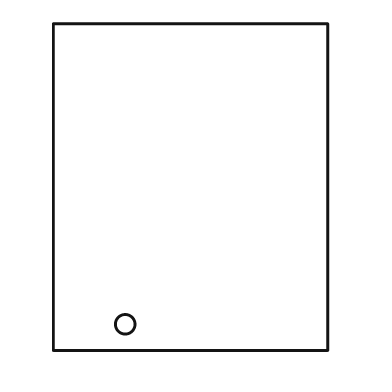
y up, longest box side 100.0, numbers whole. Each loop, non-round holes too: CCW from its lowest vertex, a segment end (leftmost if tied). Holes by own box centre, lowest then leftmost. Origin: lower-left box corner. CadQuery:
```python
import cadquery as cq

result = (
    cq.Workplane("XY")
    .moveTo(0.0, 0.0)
    .lineTo(84.0, 0.0)
    .lineTo(84.0, 100.0)
    .lineTo(0.0, 100.0)
    .close()
    .moveTo(22.0, 8.0)
    .circle(3.0)
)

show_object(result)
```